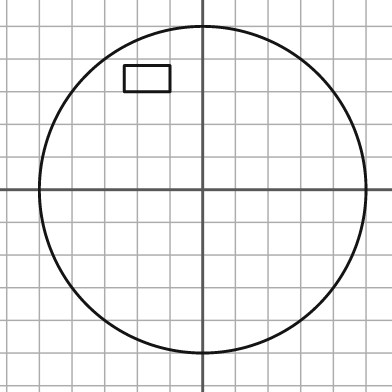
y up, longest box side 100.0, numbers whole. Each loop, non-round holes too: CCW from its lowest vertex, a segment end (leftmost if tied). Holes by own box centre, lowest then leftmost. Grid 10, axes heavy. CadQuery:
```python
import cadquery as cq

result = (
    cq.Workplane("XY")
    .moveTo(0.0, 0.0)
    .circle(50.0)
    .moveTo(-24.0, 30.0)
    .lineTo(-10.0, 30.0)
    .lineTo(-10.0, 38.0)
    .lineTo(-24.0, 38.0)
    .close()
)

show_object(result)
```